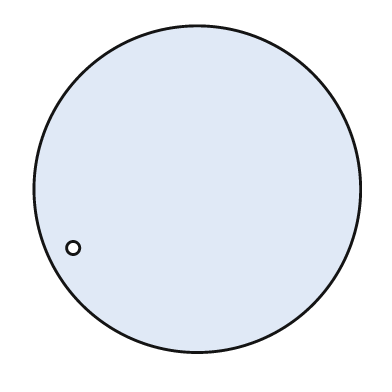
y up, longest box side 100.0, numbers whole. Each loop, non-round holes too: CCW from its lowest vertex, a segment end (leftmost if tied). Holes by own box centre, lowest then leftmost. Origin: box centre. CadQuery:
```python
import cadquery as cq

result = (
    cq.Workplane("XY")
    .moveTo(0.0, 0.0)
    .circle(50.0)
    .moveTo(-38.0, -18.0)
    .circle(2.0)
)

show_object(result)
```